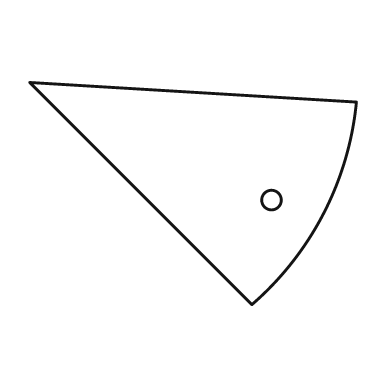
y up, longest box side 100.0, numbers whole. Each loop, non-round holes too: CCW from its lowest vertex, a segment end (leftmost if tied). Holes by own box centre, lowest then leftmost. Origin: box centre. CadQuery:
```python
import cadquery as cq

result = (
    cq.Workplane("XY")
    .moveTo(18.0, -34.0)
    .threePointArc((40.0, -6.0), (50.0, 28.0))
    .lineTo(-50.0, 34.0)
    .close()
    .moveTo(24.0, -2.0)
    .circle(3.0)
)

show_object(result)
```